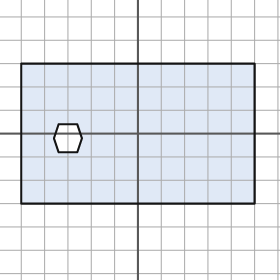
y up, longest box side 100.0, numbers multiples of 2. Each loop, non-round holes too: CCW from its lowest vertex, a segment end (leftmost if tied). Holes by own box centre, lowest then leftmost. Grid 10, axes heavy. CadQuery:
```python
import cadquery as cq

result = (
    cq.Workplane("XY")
    .moveTo(-50.0, -30.0)
    .lineTo(50.0, -30.0)
    .lineTo(50.0, 30.0)
    .lineTo(-50.0, 30.0)
    .close()
    .moveTo(-34.0, -8.0)
    .lineTo(-26.0, -8.0)
    .lineTo(-24.0, -2.0)
    .lineTo(-26.0, 4.0)
    .lineTo(-34.0, 4.0)
    .lineTo(-36.0, -2.0)
    .close()
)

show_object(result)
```